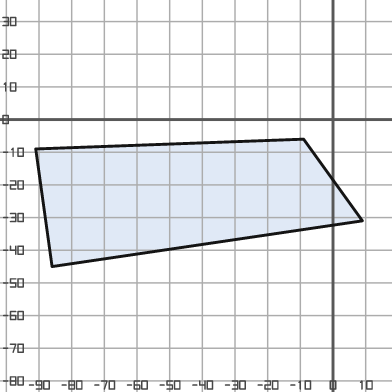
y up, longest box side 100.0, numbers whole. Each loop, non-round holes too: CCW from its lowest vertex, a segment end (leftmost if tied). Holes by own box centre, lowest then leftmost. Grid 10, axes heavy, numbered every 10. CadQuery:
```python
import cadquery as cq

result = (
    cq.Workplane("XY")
    .moveTo(-86.0, -45.0)
    .lineTo(9.0, -31.0)
    .lineTo(-9.0, -6.0)
    .lineTo(-91.0, -9.0)
    .close()
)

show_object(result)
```